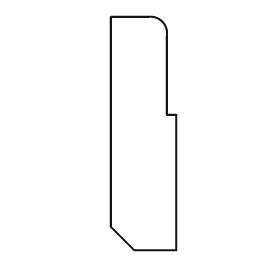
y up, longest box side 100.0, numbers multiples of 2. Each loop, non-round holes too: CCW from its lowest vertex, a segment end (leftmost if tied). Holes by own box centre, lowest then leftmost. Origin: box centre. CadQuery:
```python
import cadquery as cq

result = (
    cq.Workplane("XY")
    .moveTo(-4.0, -50.0)
    .lineTo(14.0, -50.0)
    .lineTo(14.0, 8.0)
    .lineTo(10.0, 8.0)
    .lineTo(10.0, 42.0)
    .threePointArc((8.0, 48.0), (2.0, 50.0))
    .lineTo(-14.0, 50.0)
    .lineTo(-14.0, -40.0)
    .close()
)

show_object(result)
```